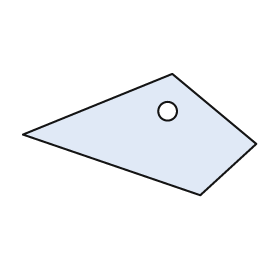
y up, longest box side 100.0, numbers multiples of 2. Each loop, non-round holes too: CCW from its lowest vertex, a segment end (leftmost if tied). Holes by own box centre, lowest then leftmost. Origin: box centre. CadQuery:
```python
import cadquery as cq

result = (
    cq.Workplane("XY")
    .moveTo(26.0, -26.0)
    .lineTo(50.0, -4.0)
    .lineTo(14.0, 26.0)
    .lineTo(-50.0, 0.0)
    .close()
    .moveTo(12.0, 10.0)
    .circle(4.0)
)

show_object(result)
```